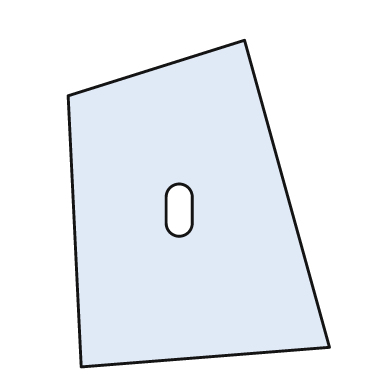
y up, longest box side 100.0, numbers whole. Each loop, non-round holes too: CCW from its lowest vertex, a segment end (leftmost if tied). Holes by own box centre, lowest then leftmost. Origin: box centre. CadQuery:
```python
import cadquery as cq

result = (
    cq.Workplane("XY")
    .moveTo(-36.0, -50.0)
    .lineTo(40.0, -44.0)
    .lineTo(14.0, 50.0)
    .lineTo(-40.0, 33.0)
    .close()
    .moveTo(-10.0, -6.0)
    .threePointArc((-6.0, -10.0), (-2.0, -6.0))
    .lineTo(-2.0, 2.0)
    .threePointArc((-6.0, 6.0), (-10.0, 2.0))
    .close()
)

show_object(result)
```